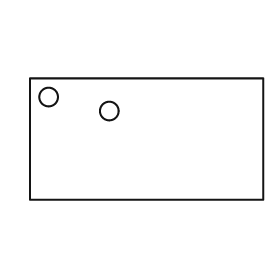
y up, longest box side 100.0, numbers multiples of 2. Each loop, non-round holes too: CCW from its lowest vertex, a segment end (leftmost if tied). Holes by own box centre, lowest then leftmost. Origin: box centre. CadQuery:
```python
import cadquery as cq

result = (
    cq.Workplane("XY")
    .moveTo(-50.0, -26.0)
    .lineTo(50.0, -26.0)
    .lineTo(50.0, 26.0)
    .lineTo(-50.0, 26.0)
    .close()
    .moveTo(-16.0, 12.0)
    .circle(4.0)
    .moveTo(-42.0, 18.0)
    .circle(4.0)
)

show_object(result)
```